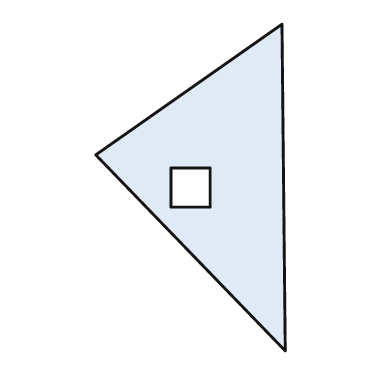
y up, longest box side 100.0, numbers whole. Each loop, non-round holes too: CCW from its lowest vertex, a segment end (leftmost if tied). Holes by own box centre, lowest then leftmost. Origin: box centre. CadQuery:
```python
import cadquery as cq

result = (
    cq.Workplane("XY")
    .moveTo(29.0, -50.0)
    .lineTo(28.0, 50.0)
    .lineTo(-29.0, 10.0)
    .close()
    .moveTo(-6.0, -6.0)
    .lineTo(6.0, -6.0)
    .lineTo(6.0, 6.0)
    .lineTo(-6.0, 6.0)
    .close()
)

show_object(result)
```